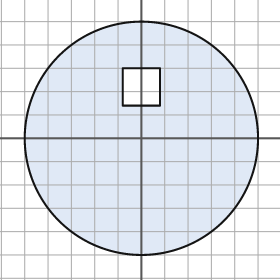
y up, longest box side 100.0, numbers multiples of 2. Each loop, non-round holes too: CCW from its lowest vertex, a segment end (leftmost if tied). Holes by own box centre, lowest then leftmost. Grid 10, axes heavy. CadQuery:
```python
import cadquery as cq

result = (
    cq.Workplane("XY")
    .moveTo(0.0, 0.0)
    .circle(50.0)
    .moveTo(-8.0, 14.0)
    .lineTo(8.0, 14.0)
    .lineTo(8.0, 30.0)
    .lineTo(-8.0, 30.0)
    .close()
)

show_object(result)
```